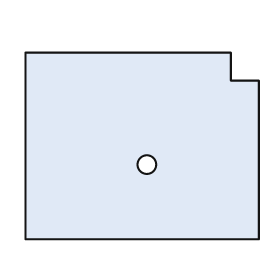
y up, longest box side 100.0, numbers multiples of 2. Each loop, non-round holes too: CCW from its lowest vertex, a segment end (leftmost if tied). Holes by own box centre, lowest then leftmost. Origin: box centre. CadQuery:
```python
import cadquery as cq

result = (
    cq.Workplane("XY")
    .moveTo(-50.0, -40.0)
    .lineTo(50.0, -40.0)
    .lineTo(50.0, 28.0)
    .lineTo(38.0, 28.0)
    .lineTo(38.0, 40.0)
    .lineTo(-50.0, 40.0)
    .close()
    .moveTo(2.0, -8.0)
    .circle(4.0)
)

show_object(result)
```